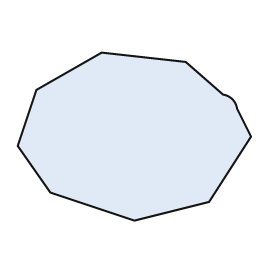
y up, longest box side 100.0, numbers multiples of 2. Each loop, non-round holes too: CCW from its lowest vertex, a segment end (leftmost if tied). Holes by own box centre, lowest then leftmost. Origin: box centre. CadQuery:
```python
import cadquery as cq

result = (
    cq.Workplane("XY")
    .moveTo(0.0, -36.0)
    .lineTo(32.0, -28.0)
    .lineTo(50.0, 0.0)
    .lineTo(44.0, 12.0)
    .threePointArc((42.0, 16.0), (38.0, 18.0))
    .lineTo(22.0, 32.0)
    .lineTo(-14.0, 36.0)
    .lineTo(-42.0, 20.0)
    .lineTo(-50.0, -4.0)
    .lineTo(-36.0, -24.0)
    .close()
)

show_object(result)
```